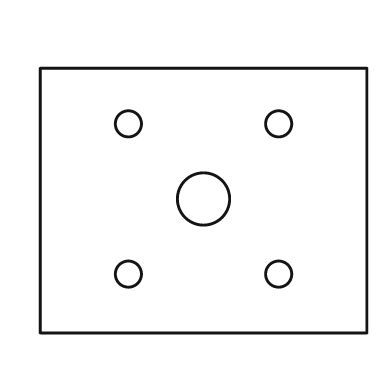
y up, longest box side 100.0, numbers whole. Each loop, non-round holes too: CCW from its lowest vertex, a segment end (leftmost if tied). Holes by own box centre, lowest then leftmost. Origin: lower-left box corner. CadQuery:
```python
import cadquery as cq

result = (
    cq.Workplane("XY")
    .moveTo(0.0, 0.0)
    .lineTo(100.0, 0.0)
    .lineTo(100.0, 81.0)
    .lineTo(0.0, 81.0)
    .close()
    .moveTo(27.0, 18.0)
    .circle(4.0)
    .moveTo(73.0, 18.0)
    .circle(4.0)
    .moveTo(50.0, 41.0)
    .circle(8.0)
    .moveTo(27.0, 64.0)
    .circle(4.0)
    .moveTo(73.0, 64.0)
    .circle(4.0)
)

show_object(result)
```